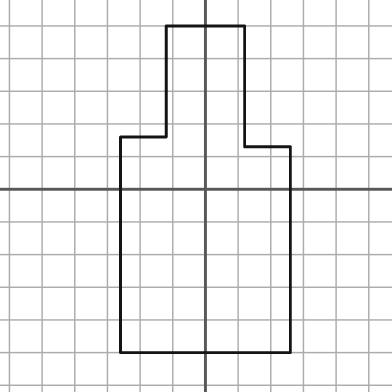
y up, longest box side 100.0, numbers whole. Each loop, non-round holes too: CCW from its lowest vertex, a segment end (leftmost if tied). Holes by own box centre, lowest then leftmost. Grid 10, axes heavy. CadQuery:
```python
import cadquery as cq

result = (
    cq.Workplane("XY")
    .moveTo(-26.0, -50.0)
    .lineTo(26.0, -50.0)
    .lineTo(26.0, 13.0)
    .lineTo(12.0, 13.0)
    .lineTo(12.0, 50.0)
    .lineTo(-12.0, 50.0)
    .lineTo(-12.0, 16.0)
    .lineTo(-26.0, 16.0)
    .close()
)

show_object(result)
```